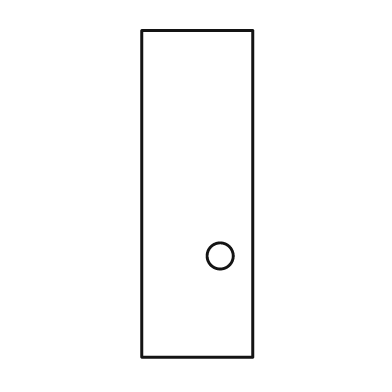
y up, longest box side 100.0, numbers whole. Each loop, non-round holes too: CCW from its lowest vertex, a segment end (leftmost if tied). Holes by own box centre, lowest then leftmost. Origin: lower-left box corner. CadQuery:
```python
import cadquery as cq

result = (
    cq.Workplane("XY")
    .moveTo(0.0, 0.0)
    .lineTo(34.0, 0.0)
    .lineTo(34.0, 100.0)
    .lineTo(0.0, 100.0)
    .close()
    .moveTo(24.0, 31.0)
    .circle(4.0)
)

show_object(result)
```